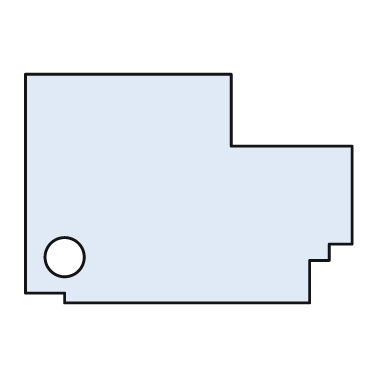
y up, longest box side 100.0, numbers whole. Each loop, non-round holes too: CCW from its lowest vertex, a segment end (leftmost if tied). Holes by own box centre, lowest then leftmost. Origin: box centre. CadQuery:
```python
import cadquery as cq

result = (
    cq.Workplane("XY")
    .moveTo(-38.0, -35.0)
    .lineTo(37.0, -35.0)
    .lineTo(37.0, -22.0)
    .lineTo(43.0, -22.0)
    .lineTo(43.0, -17.0)
    .lineTo(50.0, -17.0)
    .lineTo(50.0, 13.0)
    .lineTo(13.0, 13.0)
    .lineTo(13.0, 35.0)
    .lineTo(-50.0, 35.0)
    .lineTo(-50.0, -32.0)
    .lineTo(-38.0, -32.0)
    .close()
    .moveTo(-38.0, -21.0)
    .circle(6.0)
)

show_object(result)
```